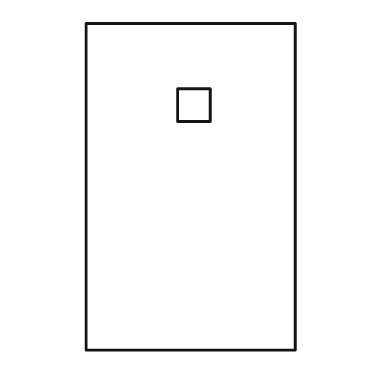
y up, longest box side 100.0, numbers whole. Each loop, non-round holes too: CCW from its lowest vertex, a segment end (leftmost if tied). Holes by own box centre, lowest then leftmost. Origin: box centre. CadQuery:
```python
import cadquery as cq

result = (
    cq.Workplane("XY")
    .moveTo(-32.0, -50.0)
    .lineTo(32.0, -50.0)
    .lineTo(32.0, 50.0)
    .lineTo(-32.0, 50.0)
    .close()
    .moveTo(-4.0, 20.0)
    .lineTo(6.0, 20.0)
    .lineTo(6.0, 30.0)
    .lineTo(-4.0, 30.0)
    .close()
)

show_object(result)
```